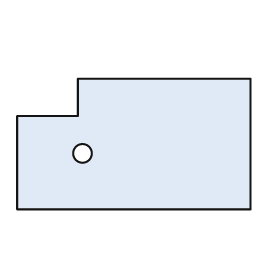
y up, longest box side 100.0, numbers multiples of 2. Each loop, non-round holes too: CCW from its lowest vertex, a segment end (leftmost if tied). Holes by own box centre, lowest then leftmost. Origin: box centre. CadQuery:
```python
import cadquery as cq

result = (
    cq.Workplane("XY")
    .moveTo(-50.0, -28.0)
    .lineTo(50.0, -28.0)
    .lineTo(50.0, 28.0)
    .lineTo(-24.0, 28.0)
    .lineTo(-24.0, 12.0)
    .lineTo(-50.0, 12.0)
    .close()
    .moveTo(-22.0, -4.0)
    .circle(4.0)
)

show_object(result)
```